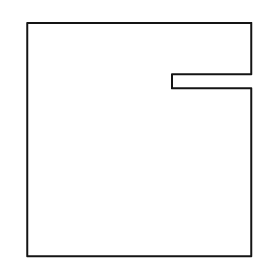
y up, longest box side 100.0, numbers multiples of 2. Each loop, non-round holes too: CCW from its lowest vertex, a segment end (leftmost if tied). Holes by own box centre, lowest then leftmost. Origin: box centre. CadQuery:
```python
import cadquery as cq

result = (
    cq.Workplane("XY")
    .moveTo(-48.0, -50.0)
    .lineTo(48.0, -50.0)
    .lineTo(48.0, 22.0)
    .lineTo(14.0, 22.0)
    .lineTo(14.0, 28.0)
    .lineTo(48.0, 28.0)
    .lineTo(48.0, 50.0)
    .lineTo(-48.0, 50.0)
    .close()
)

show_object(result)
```